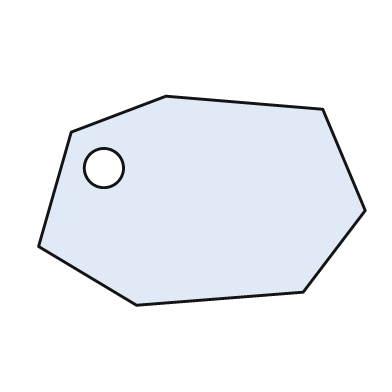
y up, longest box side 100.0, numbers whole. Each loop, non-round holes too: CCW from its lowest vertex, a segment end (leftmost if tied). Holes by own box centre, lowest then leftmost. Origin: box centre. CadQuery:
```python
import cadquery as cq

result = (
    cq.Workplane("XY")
    .moveTo(-20.0, -32.0)
    .lineTo(31.0, -28.0)
    .lineTo(50.0, -3.0)
    .lineTo(37.0, 28.0)
    .lineTo(-11.0, 32.0)
    .lineTo(-40.0, 21.0)
    .lineTo(-50.0, -14.0)
    .close()
    .moveTo(-30.0, 10.0)
    .circle(6.0)
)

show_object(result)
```